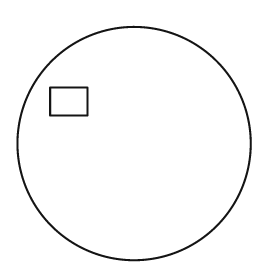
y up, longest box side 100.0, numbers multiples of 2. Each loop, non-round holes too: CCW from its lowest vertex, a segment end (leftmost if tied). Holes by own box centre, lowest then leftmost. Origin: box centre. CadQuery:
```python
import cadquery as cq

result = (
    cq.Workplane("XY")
    .moveTo(0.0, 0.0)
    .circle(50.0)
    .moveTo(-36.0, 12.0)
    .lineTo(-20.0, 12.0)
    .lineTo(-20.0, 24.0)
    .lineTo(-36.0, 24.0)
    .close()
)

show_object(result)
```